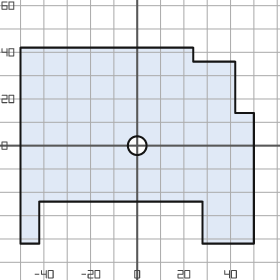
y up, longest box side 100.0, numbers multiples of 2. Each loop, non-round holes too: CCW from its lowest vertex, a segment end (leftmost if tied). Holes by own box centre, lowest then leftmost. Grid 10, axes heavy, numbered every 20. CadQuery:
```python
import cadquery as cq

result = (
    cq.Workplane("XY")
    .moveTo(-50.0, -42.0)
    .lineTo(-42.0, -42.0)
    .lineTo(-42.0, -24.0)
    .lineTo(28.0, -24.0)
    .lineTo(28.0, -42.0)
    .lineTo(50.0, -42.0)
    .lineTo(50.0, 14.0)
    .lineTo(42.0, 14.0)
    .lineTo(42.0, 36.0)
    .lineTo(24.0, 36.0)
    .lineTo(24.0, 42.0)
    .lineTo(-50.0, 42.0)
    .close()
    .moveTo(0.0, 0.0)
    .circle(4.0)
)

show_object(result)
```